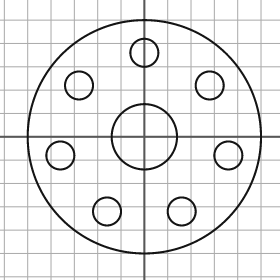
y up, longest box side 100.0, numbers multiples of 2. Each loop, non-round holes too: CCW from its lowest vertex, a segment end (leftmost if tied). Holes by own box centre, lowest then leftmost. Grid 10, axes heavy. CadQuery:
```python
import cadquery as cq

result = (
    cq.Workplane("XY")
    .moveTo(0.0, 0.0)
    .circle(50.0)
    .moveTo(-16.0, -32.0)
    .circle(6.0)
    .moveTo(16.0, -32.0)
    .circle(6.0)
    .moveTo(-36.0, -8.0)
    .circle(6.0)
    .moveTo(36.0, -8.0)
    .circle(6.0)
    .moveTo(0.0, 0.0)
    .circle(14.0)
    .moveTo(-28.0, 22.0)
    .circle(6.0)
    .moveTo(28.0, 22.0)
    .circle(6.0)
    .moveTo(0.0, 36.0)
    .circle(6.0)
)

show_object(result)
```